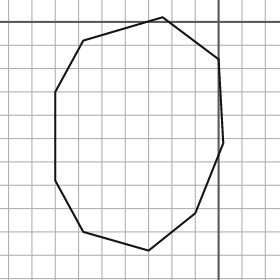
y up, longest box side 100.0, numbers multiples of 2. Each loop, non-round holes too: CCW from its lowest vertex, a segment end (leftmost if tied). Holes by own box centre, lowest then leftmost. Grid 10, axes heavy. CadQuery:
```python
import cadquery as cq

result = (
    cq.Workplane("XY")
    .moveTo(-30.0, -98.0)
    .lineTo(-10.0, -82.0)
    .lineTo(2.0, -52.0)
    .lineTo(0.0, -16.0)
    .lineTo(-24.0, 2.0)
    .lineTo(-58.0, -8.0)
    .lineTo(-70.0, -30.0)
    .lineTo(-70.0, -68.0)
    .lineTo(-58.0, -90.0)
    .close()
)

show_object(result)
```